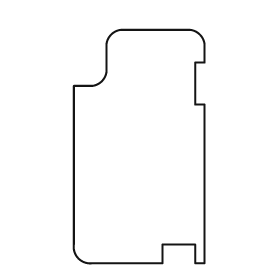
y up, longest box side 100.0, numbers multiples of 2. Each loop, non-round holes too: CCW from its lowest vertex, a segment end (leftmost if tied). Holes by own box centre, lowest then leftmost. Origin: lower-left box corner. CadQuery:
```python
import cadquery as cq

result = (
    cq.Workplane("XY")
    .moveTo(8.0, 0.0)
    .lineTo(38.0, 0.0)
    .lineTo(38.0, 8.0)
    .lineTo(52.0, 8.0)
    .lineTo(52.0, 0.0)
    .lineTo(56.0, 0.0)
    .lineTo(56.0, 68.0)
    .lineTo(52.0, 68.0)
    .lineTo(52.0, 86.0)
    .lineTo(56.0, 86.0)
    .lineTo(56.0, 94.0)
    .threePointArc((54.0, 98.0), (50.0, 100.0))
    .lineTo(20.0, 100.0)
    .threePointArc((16.0, 98.0), (14.0, 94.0))
    .lineTo(14.0, 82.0)
    .threePointArc((12.0, 78.0), (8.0, 76.0))
    .lineTo(0.0, 76.0)
    .lineTo(0.0, 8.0)
    .threePointArc((2.0, 2.0), (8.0, 0.0))
    .close()
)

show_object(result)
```